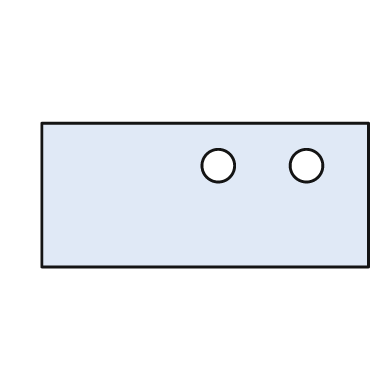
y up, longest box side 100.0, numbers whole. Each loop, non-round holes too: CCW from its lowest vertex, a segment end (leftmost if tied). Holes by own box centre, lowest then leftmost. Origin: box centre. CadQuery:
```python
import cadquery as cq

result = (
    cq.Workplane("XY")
    .moveTo(-50.0, -22.0)
    .lineTo(50.0, -22.0)
    .lineTo(50.0, 22.0)
    .lineTo(-50.0, 22.0)
    .close()
    .moveTo(4.0, 9.0)
    .circle(5.0)
    .moveTo(31.0, 9.0)
    .circle(5.0)
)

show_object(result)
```